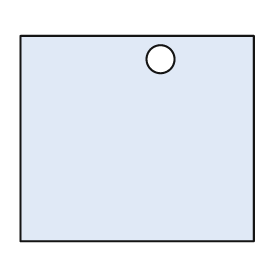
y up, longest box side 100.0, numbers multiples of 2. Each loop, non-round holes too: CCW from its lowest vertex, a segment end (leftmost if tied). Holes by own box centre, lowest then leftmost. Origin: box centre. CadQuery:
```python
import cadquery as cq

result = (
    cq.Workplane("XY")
    .moveTo(-50.0, -44.0)
    .lineTo(50.0, -44.0)
    .lineTo(50.0, 44.0)
    .lineTo(-50.0, 44.0)
    .close()
    .moveTo(10.0, 34.0)
    .circle(6.0)
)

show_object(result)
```